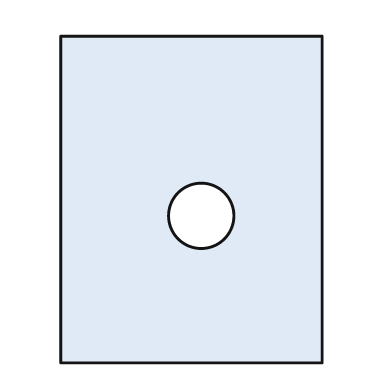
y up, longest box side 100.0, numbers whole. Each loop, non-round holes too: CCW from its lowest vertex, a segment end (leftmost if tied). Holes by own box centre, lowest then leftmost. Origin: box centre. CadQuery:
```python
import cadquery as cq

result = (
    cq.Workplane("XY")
    .moveTo(-40.0, -50.0)
    .lineTo(40.0, -50.0)
    .lineTo(40.0, 50.0)
    .lineTo(-40.0, 50.0)
    .close()
    .moveTo(3.0, -5.0)
    .circle(10.0)
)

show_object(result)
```